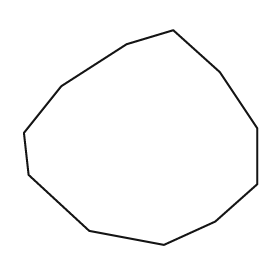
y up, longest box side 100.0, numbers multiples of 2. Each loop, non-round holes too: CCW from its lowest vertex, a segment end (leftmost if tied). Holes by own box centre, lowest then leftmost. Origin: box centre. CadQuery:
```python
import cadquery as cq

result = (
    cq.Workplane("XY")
    .moveTo(10.0, -46.0)
    .lineTo(32.0, -36.0)
    .lineTo(50.0, -20.0)
    .lineTo(50.0, 4.0)
    .lineTo(34.0, 28.0)
    .lineTo(14.0, 46.0)
    .lineTo(-6.0, 40.0)
    .lineTo(-34.0, 22.0)
    .lineTo(-50.0, 2.0)
    .lineTo(-48.0, -16.0)
    .lineTo(-22.0, -40.0)
    .close()
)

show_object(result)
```